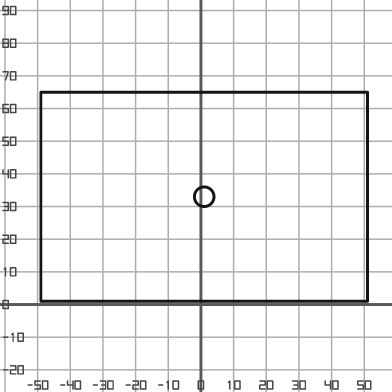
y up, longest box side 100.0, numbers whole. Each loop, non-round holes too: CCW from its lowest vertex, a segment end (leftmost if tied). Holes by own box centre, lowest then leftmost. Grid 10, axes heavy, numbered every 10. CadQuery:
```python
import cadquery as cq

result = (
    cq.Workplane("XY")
    .moveTo(-49.0, 1.0)
    .lineTo(51.0, 1.0)
    .lineTo(51.0, 65.0)
    .lineTo(-49.0, 65.0)
    .close()
    .moveTo(1.0, 33.0)
    .circle(3.0)
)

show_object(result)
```